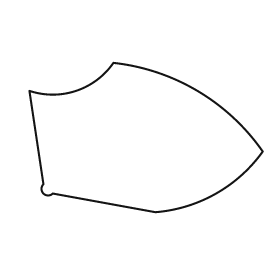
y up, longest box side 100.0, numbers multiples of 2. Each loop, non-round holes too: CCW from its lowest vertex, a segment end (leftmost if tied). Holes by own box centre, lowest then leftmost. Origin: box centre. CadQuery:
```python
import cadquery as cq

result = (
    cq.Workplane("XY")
    .moveTo(4.0, -32.0)
    .threePointArc((30.0, -24.0), (50.0, -6.0))
    .threePointArc((22.0, 20.0), (-14.0, 32.0))
    .threePointArc((-30.0, 20.0), (-50.0, 20.0))
    .lineTo(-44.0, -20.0)
    .threePointArc((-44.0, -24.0), (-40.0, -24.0))
    .close()
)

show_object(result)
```